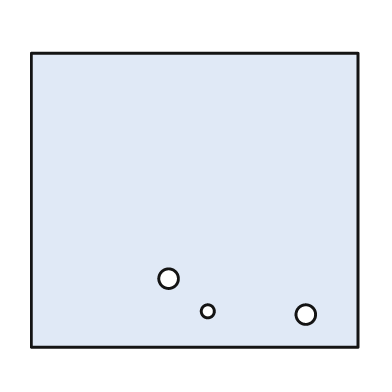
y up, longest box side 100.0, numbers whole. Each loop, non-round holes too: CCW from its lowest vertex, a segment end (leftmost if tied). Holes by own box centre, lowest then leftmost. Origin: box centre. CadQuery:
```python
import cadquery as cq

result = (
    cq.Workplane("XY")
    .moveTo(-50.0, -45.0)
    .lineTo(50.0, -45.0)
    .lineTo(50.0, 45.0)
    .lineTo(-50.0, 45.0)
    .close()
    .moveTo(34.0, -35.0)
    .circle(3.0)
    .moveTo(4.0, -34.0)
    .circle(2.0)
    .moveTo(-8.0, -24.0)
    .circle(3.0)
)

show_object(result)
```